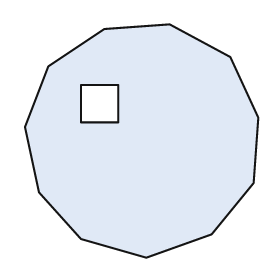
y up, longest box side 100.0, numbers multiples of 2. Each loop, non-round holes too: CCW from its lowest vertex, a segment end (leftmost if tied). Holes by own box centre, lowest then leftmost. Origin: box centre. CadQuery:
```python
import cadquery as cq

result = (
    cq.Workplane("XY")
    .moveTo(2.0, -50.0)
    .lineTo(30.0, -40.0)
    .lineTo(48.0, -18.0)
    .lineTo(50.0, 10.0)
    .lineTo(38.0, 36.0)
    .lineTo(12.0, 50.0)
    .lineTo(-16.0, 48.0)
    .lineTo(-40.0, 32.0)
    .lineTo(-50.0, 6.0)
    .lineTo(-44.0, -22.0)
    .lineTo(-26.0, -42.0)
    .close()
    .moveTo(-26.0, 8.0)
    .lineTo(-10.0, 8.0)
    .lineTo(-10.0, 24.0)
    .lineTo(-26.0, 24.0)
    .close()
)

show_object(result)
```